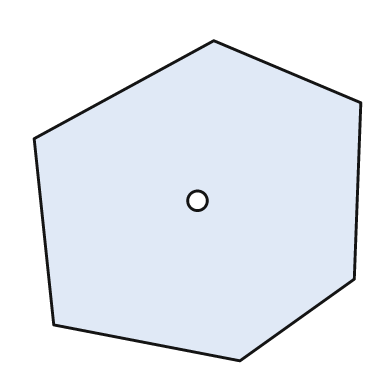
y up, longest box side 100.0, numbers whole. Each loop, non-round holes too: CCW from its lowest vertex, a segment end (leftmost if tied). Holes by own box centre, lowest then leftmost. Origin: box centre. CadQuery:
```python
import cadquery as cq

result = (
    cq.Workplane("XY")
    .moveTo(13.0, -49.0)
    .lineTo(48.0, -24.0)
    .lineTo(50.0, 30.0)
    .lineTo(5.0, 49.0)
    .lineTo(-50.0, 19.0)
    .lineTo(-44.0, -38.0)
    .close()
    .moveTo(0.0, 0.0)
    .circle(3.0)
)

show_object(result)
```